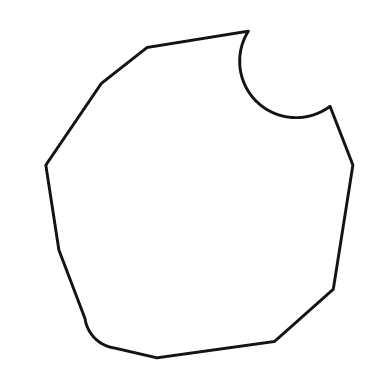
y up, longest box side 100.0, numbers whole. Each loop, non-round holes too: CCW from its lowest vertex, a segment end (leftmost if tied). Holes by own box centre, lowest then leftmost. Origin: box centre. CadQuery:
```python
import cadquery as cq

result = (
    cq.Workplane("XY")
    .moveTo(-13.0, -50.0)
    .lineTo(23.0, -45.0)
    .lineTo(41.0, -29.0)
    .lineTo(47.0, 9.0)
    .lineTo(40.0, 27.0)
    .threePointArc((18.0, 28.0), (15.0, 50.0))
    .lineTo(-16.0, 45.0)
    .lineTo(-30.0, 34.0)
    .lineTo(-47.0, 9.0)
    .lineTo(-43.0, -17.0)
    .lineTo(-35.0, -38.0)
    .threePointArc((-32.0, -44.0), (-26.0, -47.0))
    .close()
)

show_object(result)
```